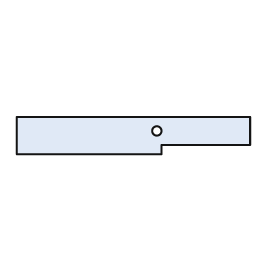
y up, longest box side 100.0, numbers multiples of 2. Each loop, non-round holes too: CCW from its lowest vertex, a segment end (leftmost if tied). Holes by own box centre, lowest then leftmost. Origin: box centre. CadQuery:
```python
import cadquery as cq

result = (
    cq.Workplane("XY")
    .moveTo(-50.0, -8.0)
    .lineTo(12.0, -8.0)
    .lineTo(12.0, -4.0)
    .lineTo(50.0, -4.0)
    .lineTo(50.0, 8.0)
    .lineTo(-50.0, 8.0)
    .close()
    .moveTo(10.0, 2.0)
    .circle(2.0)
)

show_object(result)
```